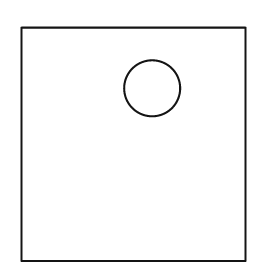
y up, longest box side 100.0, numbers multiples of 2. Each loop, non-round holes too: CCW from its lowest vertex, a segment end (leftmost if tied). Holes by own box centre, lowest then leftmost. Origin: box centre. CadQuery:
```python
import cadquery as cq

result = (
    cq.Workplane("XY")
    .moveTo(-48.0, -50.0)
    .lineTo(48.0, -50.0)
    .lineTo(48.0, 50.0)
    .lineTo(-48.0, 50.0)
    .close()
    .moveTo(8.0, 24.0)
    .circle(12.0)
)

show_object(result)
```